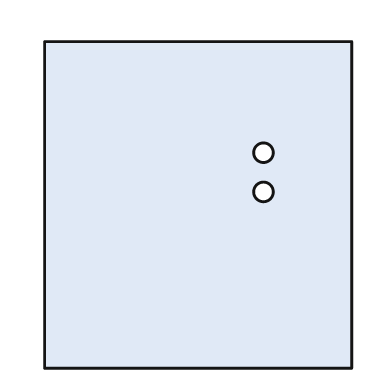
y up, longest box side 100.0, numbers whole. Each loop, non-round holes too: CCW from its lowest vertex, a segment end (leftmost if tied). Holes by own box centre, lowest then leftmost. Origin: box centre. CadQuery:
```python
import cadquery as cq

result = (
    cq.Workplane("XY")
    .moveTo(-47.0, -50.0)
    .lineTo(47.0, -50.0)
    .lineTo(47.0, 50.0)
    .lineTo(-47.0, 50.0)
    .close()
    .moveTo(20.0, 4.0)
    .circle(3.0)
    .moveTo(20.0, 16.0)
    .circle(3.0)
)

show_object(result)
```